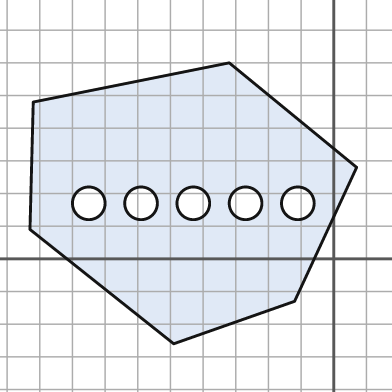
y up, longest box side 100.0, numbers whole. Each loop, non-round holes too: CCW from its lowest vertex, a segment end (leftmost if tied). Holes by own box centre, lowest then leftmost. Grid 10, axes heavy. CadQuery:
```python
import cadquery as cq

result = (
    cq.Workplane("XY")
    .moveTo(-49.0, -26.0)
    .lineTo(-12.0, -13.0)
    .lineTo(7.0, 28.0)
    .lineTo(-32.0, 60.0)
    .lineTo(-92.0, 48.0)
    .lineTo(-93.0, 9.0)
    .close()
    .moveTo(-75.0, 17.0)
    .circle(5.0)
    .moveTo(-59.0, 17.0)
    .circle(5.0)
    .moveTo(-43.0, 17.0)
    .circle(5.0)
    .moveTo(-27.0, 17.0)
    .circle(5.0)
    .moveTo(-11.0, 17.0)
    .circle(5.0)
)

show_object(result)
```